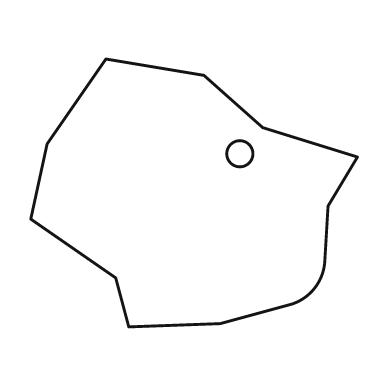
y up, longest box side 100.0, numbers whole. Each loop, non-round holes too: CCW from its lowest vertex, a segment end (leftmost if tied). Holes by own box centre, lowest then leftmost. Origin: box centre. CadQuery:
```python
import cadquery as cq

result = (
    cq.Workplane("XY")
    .moveTo(-20.0, -41.0)
    .lineTo(8.0, -40.0)
    .lineTo(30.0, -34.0)
    .threePointArc((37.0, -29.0), (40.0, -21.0))
    .lineTo(41.0, -4.0)
    .lineTo(50.0, 11.0)
    .lineTo(21.0, 20.0)
    .lineTo(3.0, 36.0)
    .lineTo(-27.0, 41.0)
    .lineTo(-45.0, 15.0)
    .lineTo(-50.0, -8.0)
    .lineTo(-24.0, -26.0)
    .close()
    .moveTo(14.0, 12.0)
    .circle(4.0)
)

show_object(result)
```